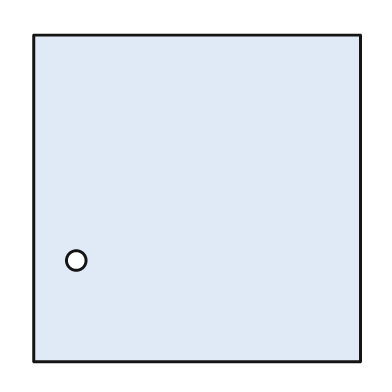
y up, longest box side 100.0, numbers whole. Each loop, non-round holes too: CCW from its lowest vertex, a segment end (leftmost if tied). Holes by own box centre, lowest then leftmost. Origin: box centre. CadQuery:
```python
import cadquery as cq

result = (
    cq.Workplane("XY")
    .moveTo(-50.0, -50.0)
    .lineTo(50.0, -50.0)
    .lineTo(50.0, 50.0)
    .lineTo(-50.0, 50.0)
    .close()
    .moveTo(-37.0, -19.0)
    .circle(3.0)
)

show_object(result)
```